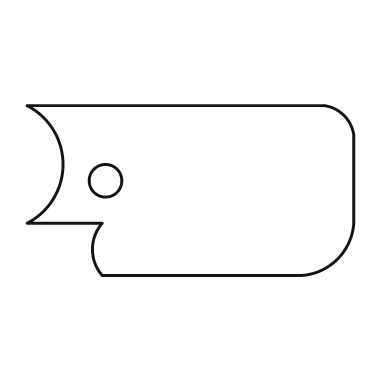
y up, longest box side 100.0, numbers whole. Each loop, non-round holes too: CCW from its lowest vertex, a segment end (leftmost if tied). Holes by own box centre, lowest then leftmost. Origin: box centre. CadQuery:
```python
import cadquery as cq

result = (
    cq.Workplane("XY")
    .moveTo(-27.0, -26.0)
    .lineTo(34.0, -26.0)
    .threePointArc((45.0, -21.0), (50.0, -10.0))
    .lineTo(50.0, 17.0)
    .threePointArc((47.0, 23.0), (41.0, 26.0))
    .lineTo(-50.0, 26.0)
    .threePointArc((-39.0, 8.0), (-50.0, -10.0))
    .lineTo(-27.0, -10.0)
    .threePointArc((-30.0, -18.0), (-27.0, -26.0))
    .close()
    .moveTo(-26.0, 3.0)
    .circle(5.0)
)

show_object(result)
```